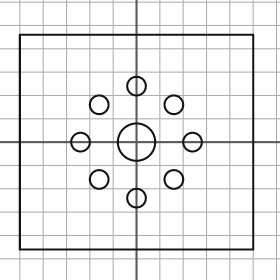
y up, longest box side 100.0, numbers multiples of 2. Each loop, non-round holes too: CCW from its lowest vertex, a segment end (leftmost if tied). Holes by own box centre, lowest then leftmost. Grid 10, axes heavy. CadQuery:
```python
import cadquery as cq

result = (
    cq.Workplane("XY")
    .moveTo(-50.0, -46.0)
    .lineTo(50.0, -46.0)
    .lineTo(50.0, 46.0)
    .lineTo(-50.0, 46.0)
    .close()
    .moveTo(0.0, -24.0)
    .circle(4.0)
    .moveTo(-16.0, -16.0)
    .circle(4.0)
    .moveTo(16.0, -16.0)
    .circle(4.0)
    .moveTo(-24.0, 0.0)
    .circle(4.0)
    .moveTo(0.0, 0.0)
    .circle(8.0)
    .moveTo(24.0, 0.0)
    .circle(4.0)
    .moveTo(-16.0, 16.0)
    .circle(4.0)
    .moveTo(16.0, 16.0)
    .circle(4.0)
    .moveTo(0.0, 24.0)
    .circle(4.0)
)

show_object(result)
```